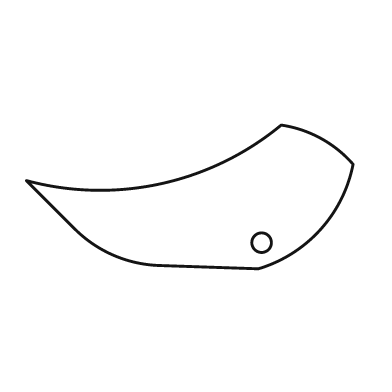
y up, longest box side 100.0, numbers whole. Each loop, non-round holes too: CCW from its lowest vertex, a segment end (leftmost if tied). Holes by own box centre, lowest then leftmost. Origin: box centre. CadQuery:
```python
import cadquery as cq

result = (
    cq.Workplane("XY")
    .moveTo(21.0, -22.0)
    .threePointArc((40.0, -10.0), (50.0, 10.0))
    .threePointArc((40.0, 18.0), (28.0, 22.0))
    .threePointArc((-9.0, 4.0), (-50.0, 5.0))
    .lineTo(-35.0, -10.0)
    .threePointArc((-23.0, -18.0), (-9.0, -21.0))
    .close()
    .moveTo(22.0, -14.0)
    .circle(3.0)
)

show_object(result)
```